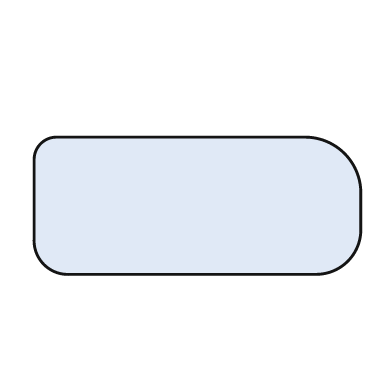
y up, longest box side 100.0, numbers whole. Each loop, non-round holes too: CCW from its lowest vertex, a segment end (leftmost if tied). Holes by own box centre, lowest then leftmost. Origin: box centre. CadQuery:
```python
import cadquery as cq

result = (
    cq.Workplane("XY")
    .moveTo(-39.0, -21.0)
    .lineTo(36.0, -21.0)
    .threePointArc((46.0, -17.0), (50.0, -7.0))
    .lineTo(50.0, 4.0)
    .threePointArc((45.0, 16.0), (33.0, 21.0))
    .lineTo(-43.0, 21.0)
    .threePointArc((-48.0, 19.0), (-50.0, 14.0))
    .lineTo(-50.0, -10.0)
    .threePointArc((-47.0, -18.0), (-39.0, -21.0))
    .close()
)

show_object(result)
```